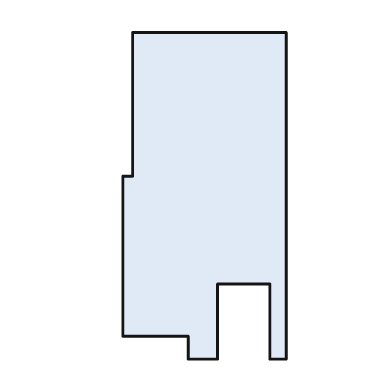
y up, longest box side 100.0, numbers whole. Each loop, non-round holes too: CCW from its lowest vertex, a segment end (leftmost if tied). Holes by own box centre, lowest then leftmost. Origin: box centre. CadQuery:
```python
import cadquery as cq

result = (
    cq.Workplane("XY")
    .moveTo(-5.0, -50.0)
    .lineTo(4.0, -50.0)
    .lineTo(4.0, -27.0)
    .lineTo(20.0, -27.0)
    .lineTo(20.0, -50.0)
    .lineTo(25.0, -50.0)
    .lineTo(25.0, 50.0)
    .lineTo(-22.0, 50.0)
    .lineTo(-22.0, 6.0)
    .lineTo(-25.0, 6.0)
    .lineTo(-25.0, -43.0)
    .lineTo(-5.0, -43.0)
    .close()
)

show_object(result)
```